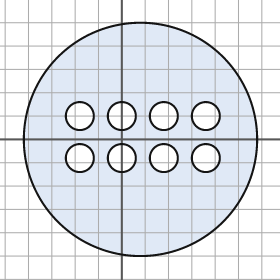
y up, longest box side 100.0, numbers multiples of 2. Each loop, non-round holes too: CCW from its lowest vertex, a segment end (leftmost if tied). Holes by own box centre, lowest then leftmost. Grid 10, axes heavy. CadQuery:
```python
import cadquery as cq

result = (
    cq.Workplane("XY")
    .moveTo(8.0, 0.0)
    .circle(50.0)
    .moveTo(-18.0, -8.0)
    .circle(6.0)
    .moveTo(0.0, -8.0)
    .circle(6.0)
    .moveTo(18.0, -8.0)
    .circle(6.0)
    .moveTo(36.0, -8.0)
    .circle(6.0)
    .moveTo(-18.0, 10.0)
    .circle(6.0)
    .moveTo(0.0, 10.0)
    .circle(6.0)
    .moveTo(18.0, 10.0)
    .circle(6.0)
    .moveTo(36.0, 10.0)
    .circle(6.0)
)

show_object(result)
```